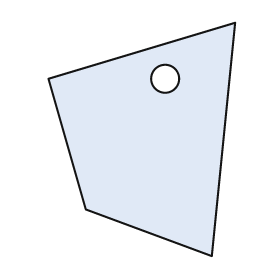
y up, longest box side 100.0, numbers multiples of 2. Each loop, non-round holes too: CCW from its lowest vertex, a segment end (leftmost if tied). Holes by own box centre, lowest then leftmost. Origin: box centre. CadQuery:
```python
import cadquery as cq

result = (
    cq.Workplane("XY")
    .moveTo(30.0, -50.0)
    .lineTo(40.0, 50.0)
    .lineTo(-40.0, 26.0)
    .lineTo(-24.0, -30.0)
    .close()
    .moveTo(10.0, 26.0)
    .circle(6.0)
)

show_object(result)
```